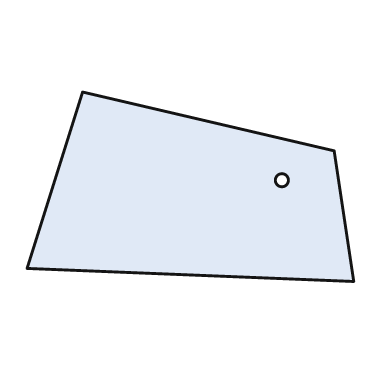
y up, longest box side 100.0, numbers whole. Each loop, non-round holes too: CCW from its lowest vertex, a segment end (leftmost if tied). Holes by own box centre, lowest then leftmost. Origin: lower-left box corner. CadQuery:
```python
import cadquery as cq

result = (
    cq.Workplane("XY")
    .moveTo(100.0, 0.0)
    .lineTo(94.0, 40.0)
    .lineTo(17.0, 58.0)
    .lineTo(0.0, 4.0)
    .close()
    .moveTo(78.0, 31.0)
    .circle(2.0)
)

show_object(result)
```